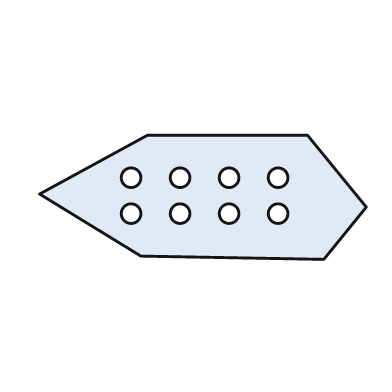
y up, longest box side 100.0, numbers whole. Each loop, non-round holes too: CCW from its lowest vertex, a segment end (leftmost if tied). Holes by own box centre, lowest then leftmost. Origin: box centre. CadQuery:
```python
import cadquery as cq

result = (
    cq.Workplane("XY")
    .moveTo(37.0, -19.0)
    .lineTo(50.0, -3.0)
    .lineTo(32.0, 19.0)
    .lineTo(-17.0, 19.0)
    .lineTo(-50.0, 1.0)
    .lineTo(-19.0, -18.0)
    .close()
    .moveTo(-22.0, -5.0)
    .circle(3.0)
    .moveTo(-7.0, -5.0)
    .circle(3.0)
    .moveTo(8.0, -5.0)
    .circle(3.0)
    .moveTo(23.0, -5.0)
    .circle(3.0)
    .moveTo(-22.0, 6.0)
    .circle(3.0)
    .moveTo(-7.0, 6.0)
    .circle(3.0)
    .moveTo(8.0, 6.0)
    .circle(3.0)
    .moveTo(23.0, 6.0)
    .circle(3.0)
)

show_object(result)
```